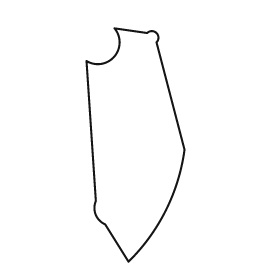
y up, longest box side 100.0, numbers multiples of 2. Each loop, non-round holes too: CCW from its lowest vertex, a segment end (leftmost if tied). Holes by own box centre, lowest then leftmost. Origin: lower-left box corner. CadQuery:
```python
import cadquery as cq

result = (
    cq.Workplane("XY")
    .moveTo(18.0, 0.0)
    .threePointArc((34.0, 22.0), (42.0, 48.0))
    .lineTo(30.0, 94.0)
    .threePointArc((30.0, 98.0), (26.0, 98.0))
    .lineTo(12.0, 100.0)
    .threePointArc((12.0, 88.0), (0.0, 86.0))
    .lineTo(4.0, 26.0)
    .threePointArc((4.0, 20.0), (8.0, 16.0))
    .close()
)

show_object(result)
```